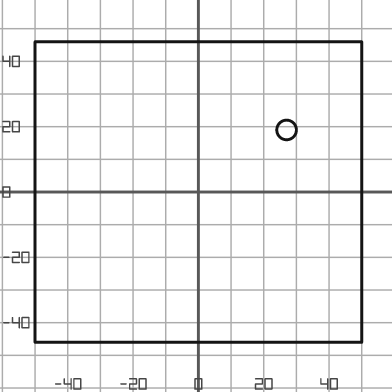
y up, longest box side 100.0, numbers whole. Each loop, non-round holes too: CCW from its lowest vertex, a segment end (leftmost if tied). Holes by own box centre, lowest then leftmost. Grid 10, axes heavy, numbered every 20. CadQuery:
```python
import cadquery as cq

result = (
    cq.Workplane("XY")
    .moveTo(-50.0, -46.0)
    .lineTo(50.0, -46.0)
    .lineTo(50.0, 46.0)
    .lineTo(-50.0, 46.0)
    .close()
    .moveTo(27.0, 19.0)
    .circle(3.0)
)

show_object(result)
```